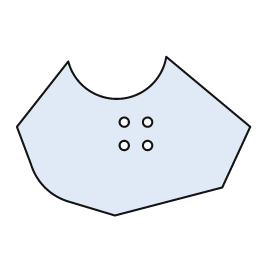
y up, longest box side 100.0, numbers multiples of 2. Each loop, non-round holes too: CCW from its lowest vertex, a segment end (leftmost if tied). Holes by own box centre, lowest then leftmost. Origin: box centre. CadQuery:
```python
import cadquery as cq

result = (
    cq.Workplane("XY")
    .moveTo(-8.0, -34.0)
    .lineTo(38.0, -22.0)
    .lineTo(50.0, 4.0)
    .lineTo(14.0, 34.0)
    .threePointArc((-6.0, 16.0), (-28.0, 32.0))
    .lineTo(-50.0, 4.0)
    .lineTo(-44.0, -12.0)
    .threePointArc((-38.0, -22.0), (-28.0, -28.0))
    .close()
    .moveTo(-4.0, -4.0)
    .circle(2.0)
    .moveTo(6.0, -4.0)
    .circle(2.0)
    .moveTo(-4.0, 6.0)
    .circle(2.0)
    .moveTo(6.0, 6.0)
    .circle(2.0)
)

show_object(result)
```